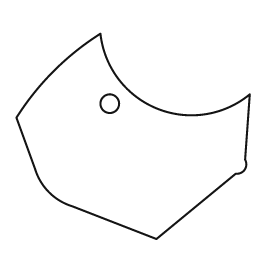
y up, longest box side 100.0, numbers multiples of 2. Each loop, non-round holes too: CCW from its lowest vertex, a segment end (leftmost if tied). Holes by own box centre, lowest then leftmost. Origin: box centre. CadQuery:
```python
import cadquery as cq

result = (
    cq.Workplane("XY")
    .moveTo(10.0, -44.0)
    .lineTo(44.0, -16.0)
    .threePointArc((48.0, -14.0), (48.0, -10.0))
    .lineTo(50.0, 18.0)
    .threePointArc((10.0, 12.0), (-14.0, 44.0))
    .threePointArc((-34.0, 28.0), (-50.0, 8.0))
    .lineTo(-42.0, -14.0)
    .threePointArc((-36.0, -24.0), (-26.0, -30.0))
    .close()
    .moveTo(-10.0, 14.0)
    .circle(4.0)
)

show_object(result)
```